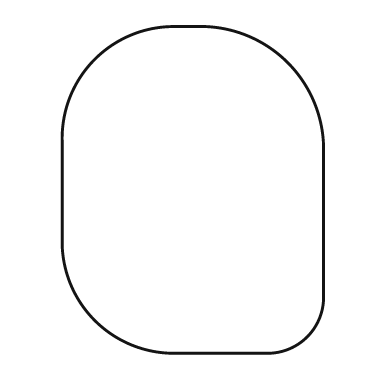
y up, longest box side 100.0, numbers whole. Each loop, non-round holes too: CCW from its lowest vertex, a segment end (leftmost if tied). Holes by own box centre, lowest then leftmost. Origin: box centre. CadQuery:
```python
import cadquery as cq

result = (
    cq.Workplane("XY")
    .moveTo(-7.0, -50.0)
    .lineTo(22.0, -50.0)
    .threePointArc((35.0, -45.0), (40.0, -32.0))
    .lineTo(40.0, 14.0)
    .threePointArc((29.0, 39.0), (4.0, 50.0))
    .lineTo(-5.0, 50.0)
    .threePointArc((-30.0, 40.0), (-40.0, 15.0))
    .lineTo(-40.0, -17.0)
    .threePointArc((-30.0, -40.0), (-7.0, -50.0))
    .close()
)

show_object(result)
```